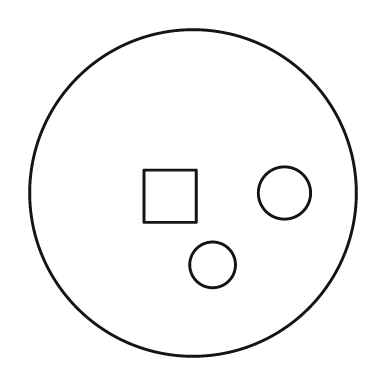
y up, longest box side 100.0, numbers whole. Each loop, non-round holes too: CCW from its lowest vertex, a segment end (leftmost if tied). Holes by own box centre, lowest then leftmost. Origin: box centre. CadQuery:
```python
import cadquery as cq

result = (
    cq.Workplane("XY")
    .moveTo(0.0, 0.0)
    .circle(50.0)
    .moveTo(6.0, -22.0)
    .circle(7.0)
    .moveTo(-15.0, -9.0)
    .lineTo(1.0, -9.0)
    .lineTo(1.0, 7.0)
    .lineTo(-15.0, 7.0)
    .close()
    .moveTo(28.0, 0.0)
    .circle(8.0)
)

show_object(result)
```